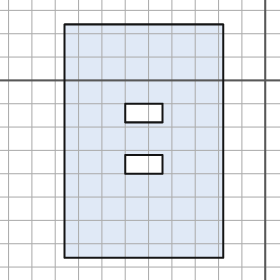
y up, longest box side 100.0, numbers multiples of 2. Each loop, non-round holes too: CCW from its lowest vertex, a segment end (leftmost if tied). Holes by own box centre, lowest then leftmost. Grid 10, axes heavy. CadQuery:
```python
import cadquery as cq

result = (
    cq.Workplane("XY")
    .moveTo(-86.0, -76.0)
    .lineTo(-18.0, -76.0)
    .lineTo(-18.0, 24.0)
    .lineTo(-86.0, 24.0)
    .close()
    .moveTo(-60.0, -40.0)
    .lineTo(-44.0, -40.0)
    .lineTo(-44.0, -32.0)
    .lineTo(-60.0, -32.0)
    .close()
    .moveTo(-60.0, -18.0)
    .lineTo(-44.0, -18.0)
    .lineTo(-44.0, -10.0)
    .lineTo(-60.0, -10.0)
    .close()
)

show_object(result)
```